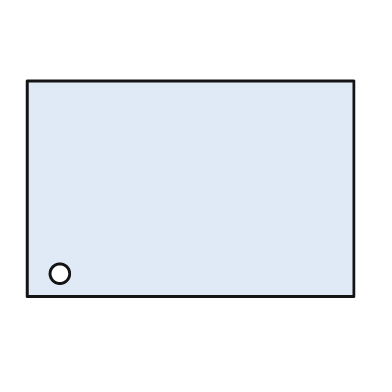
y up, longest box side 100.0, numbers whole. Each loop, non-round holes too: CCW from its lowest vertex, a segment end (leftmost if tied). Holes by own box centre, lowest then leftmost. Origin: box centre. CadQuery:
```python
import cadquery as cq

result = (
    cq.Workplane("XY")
    .moveTo(-50.0, -33.0)
    .lineTo(50.0, -33.0)
    .lineTo(50.0, 33.0)
    .lineTo(-50.0, 33.0)
    .close()
    .moveTo(-40.0, -26.0)
    .circle(3.0)
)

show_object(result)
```